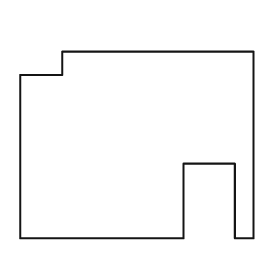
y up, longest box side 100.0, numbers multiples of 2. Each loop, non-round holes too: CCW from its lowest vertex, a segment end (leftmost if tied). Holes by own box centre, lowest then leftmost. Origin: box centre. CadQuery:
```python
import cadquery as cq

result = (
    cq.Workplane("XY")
    .moveTo(-50.0, -40.0)
    .lineTo(20.0, -40.0)
    .lineTo(20.0, -8.0)
    .lineTo(42.0, -8.0)
    .lineTo(42.0, -40.0)
    .lineTo(50.0, -40.0)
    .lineTo(50.0, 40.0)
    .lineTo(-32.0, 40.0)
    .lineTo(-32.0, 30.0)
    .lineTo(-50.0, 30.0)
    .close()
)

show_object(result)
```